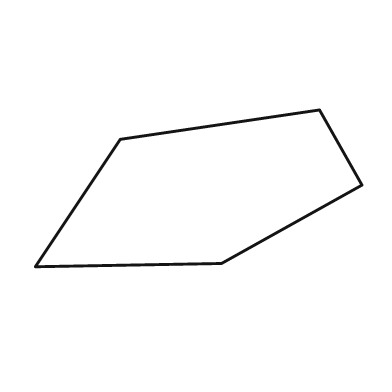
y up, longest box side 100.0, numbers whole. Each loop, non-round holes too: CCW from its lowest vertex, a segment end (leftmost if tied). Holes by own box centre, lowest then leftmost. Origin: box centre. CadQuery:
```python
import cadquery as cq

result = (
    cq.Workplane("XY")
    .moveTo(-50.0, -24.0)
    .lineTo(7.0, -23.0)
    .lineTo(50.0, 1.0)
    .lineTo(37.0, 24.0)
    .lineTo(-24.0, 15.0)
    .close()
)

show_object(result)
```